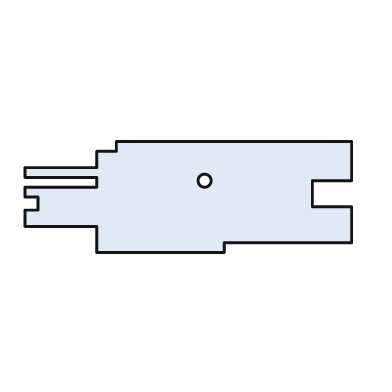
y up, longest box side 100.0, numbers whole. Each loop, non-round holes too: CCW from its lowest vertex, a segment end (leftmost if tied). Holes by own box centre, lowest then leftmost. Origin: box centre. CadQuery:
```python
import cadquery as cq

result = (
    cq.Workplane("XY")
    .moveTo(-28.0, -17.0)
    .lineTo(11.0, -17.0)
    .lineTo(11.0, -14.0)
    .lineTo(50.0, -14.0)
    .lineTo(50.0, -3.0)
    .lineTo(38.0, -3.0)
    .lineTo(38.0, 5.0)
    .lineTo(50.0, 5.0)
    .lineTo(50.0, 17.0)
    .lineTo(-22.0, 17.0)
    .lineTo(-22.0, 14.0)
    .lineTo(-28.0, 14.0)
    .lineTo(-28.0, 9.0)
    .lineTo(-50.0, 9.0)
    .lineTo(-50.0, 6.0)
    .lineTo(-28.0, 6.0)
    .lineTo(-28.0, 3.0)
    .lineTo(-50.0, 3.0)
    .lineTo(-50.0, 0.0)
    .lineTo(-46.0, 0.0)
    .lineTo(-46.0, -4.0)
    .lineTo(-50.0, -4.0)
    .lineTo(-50.0, -9.0)
    .lineTo(-28.0, -9.0)
    .close()
    .moveTo(5.0, 5.0)
    .circle(2.0)
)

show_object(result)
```